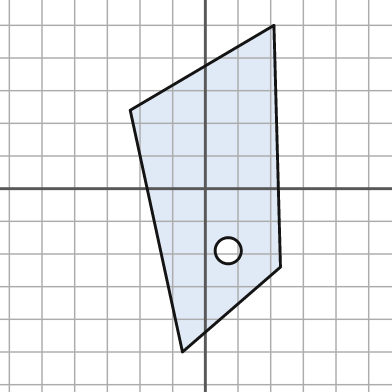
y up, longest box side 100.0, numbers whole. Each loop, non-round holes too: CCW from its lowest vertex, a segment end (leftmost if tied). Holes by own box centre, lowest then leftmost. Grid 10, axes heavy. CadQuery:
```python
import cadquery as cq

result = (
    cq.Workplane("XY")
    .moveTo(-7.0, -50.0)
    .lineTo(23.0, -24.0)
    .lineTo(21.0, 50.0)
    .lineTo(-23.0, 24.0)
    .close()
    .moveTo(7.0, -19.0)
    .circle(4.0)
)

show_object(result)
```